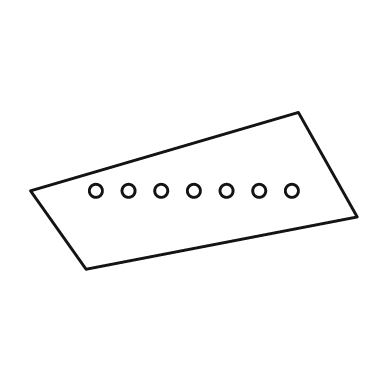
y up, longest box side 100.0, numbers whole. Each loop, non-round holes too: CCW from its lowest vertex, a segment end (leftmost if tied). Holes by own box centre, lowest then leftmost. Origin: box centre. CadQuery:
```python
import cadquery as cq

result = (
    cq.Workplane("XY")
    .moveTo(-33.0, -24.0)
    .lineTo(50.0, -8.0)
    .lineTo(32.0, 24.0)
    .lineTo(-50.0, 0.0)
    .close()
    .moveTo(-30.0, 0.0)
    .circle(2.0)
    .moveTo(-20.0, 0.0)
    .circle(2.0)
    .moveTo(-10.0, 0.0)
    .circle(2.0)
    .moveTo(0.0, 0.0)
    .circle(2.0)
    .moveTo(10.0, 0.0)
    .circle(2.0)
    .moveTo(20.0, 0.0)
    .circle(2.0)
    .moveTo(30.0, 0.0)
    .circle(2.0)
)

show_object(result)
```